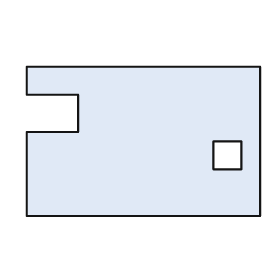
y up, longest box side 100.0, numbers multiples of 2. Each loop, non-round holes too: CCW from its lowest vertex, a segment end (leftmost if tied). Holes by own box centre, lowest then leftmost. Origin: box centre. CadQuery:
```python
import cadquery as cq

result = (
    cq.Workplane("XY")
    .moveTo(-50.0, -32.0)
    .lineTo(50.0, -32.0)
    .lineTo(50.0, 32.0)
    .lineTo(-50.0, 32.0)
    .lineTo(-50.0, 20.0)
    .lineTo(-28.0, 20.0)
    .lineTo(-28.0, 4.0)
    .lineTo(-50.0, 4.0)
    .close()
    .moveTo(30.0, -12.0)
    .lineTo(42.0, -12.0)
    .lineTo(42.0, 0.0)
    .lineTo(30.0, 0.0)
    .close()
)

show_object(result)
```